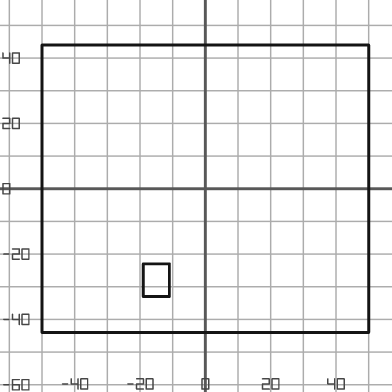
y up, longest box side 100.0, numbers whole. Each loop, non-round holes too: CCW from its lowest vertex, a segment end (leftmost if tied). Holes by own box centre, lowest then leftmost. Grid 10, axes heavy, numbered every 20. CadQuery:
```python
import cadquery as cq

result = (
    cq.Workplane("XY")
    .moveTo(-50.0, -44.0)
    .lineTo(50.0, -44.0)
    .lineTo(50.0, 44.0)
    .lineTo(-50.0, 44.0)
    .close()
    .moveTo(-19.0, -33.0)
    .lineTo(-11.0, -33.0)
    .lineTo(-11.0, -23.0)
    .lineTo(-19.0, -23.0)
    .close()
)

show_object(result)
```